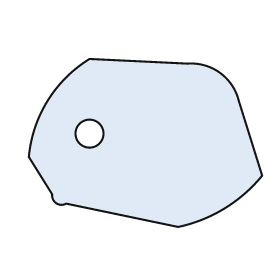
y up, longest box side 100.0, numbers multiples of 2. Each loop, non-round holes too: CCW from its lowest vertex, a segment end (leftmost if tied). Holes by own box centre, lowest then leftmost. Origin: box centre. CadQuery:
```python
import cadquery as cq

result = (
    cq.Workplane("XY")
    .moveTo(14.0, -36.0)
    .threePointArc((34.0, -28.0), (50.0, -14.0))
    .lineTo(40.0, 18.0)
    .threePointArc((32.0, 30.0), (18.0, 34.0))
    .lineTo(-24.0, 36.0)
    .threePointArc((-42.0, 18.0), (-50.0, -6.0))
    .lineTo(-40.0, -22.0)
    .threePointArc((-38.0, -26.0), (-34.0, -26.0))
    .close()
    .moveTo(-24.0, 4.0)
    .circle(6.0)
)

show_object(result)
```